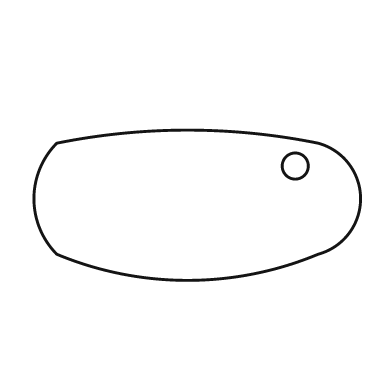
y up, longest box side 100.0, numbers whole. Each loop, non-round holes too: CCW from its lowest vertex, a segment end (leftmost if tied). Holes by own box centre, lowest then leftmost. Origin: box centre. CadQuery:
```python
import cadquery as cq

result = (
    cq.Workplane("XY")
    .moveTo(-43.0, -15.0)
    .threePointArc((-3.0, -23.0), (37.0, -15.0))
    .threePointArc((50.0, 2.0), (37.0, 19.0))
    .threePointArc((-3.0, 23.0), (-43.0, 19.0))
    .threePointArc((-50.0, 2.0), (-43.0, -15.0))
    .close()
    .moveTo(30.0, 12.0)
    .circle(4.0)
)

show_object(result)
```